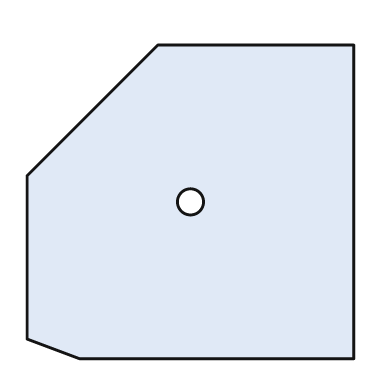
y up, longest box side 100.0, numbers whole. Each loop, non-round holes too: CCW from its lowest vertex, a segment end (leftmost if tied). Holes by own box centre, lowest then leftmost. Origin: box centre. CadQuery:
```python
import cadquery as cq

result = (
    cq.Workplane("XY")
    .moveTo(-34.0, -48.0)
    .lineTo(50.0, -48.0)
    .lineTo(50.0, 48.0)
    .lineTo(-10.0, 48.0)
    .lineTo(-50.0, 8.0)
    .lineTo(-50.0, -42.0)
    .close()
    .moveTo(0.0, 0.0)
    .circle(4.0)
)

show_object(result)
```